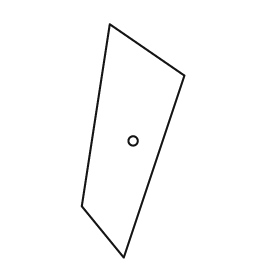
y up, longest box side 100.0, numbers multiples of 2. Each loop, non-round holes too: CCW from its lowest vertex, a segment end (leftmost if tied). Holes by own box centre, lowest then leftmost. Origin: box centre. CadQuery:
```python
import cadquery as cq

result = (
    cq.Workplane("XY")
    .moveTo(-4.0, -50.0)
    .lineTo(22.0, 28.0)
    .lineTo(-10.0, 50.0)
    .lineTo(-22.0, -28.0)
    .close()
    .moveTo(0.0, 0.0)
    .circle(2.0)
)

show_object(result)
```